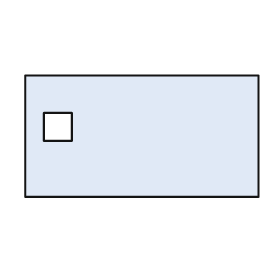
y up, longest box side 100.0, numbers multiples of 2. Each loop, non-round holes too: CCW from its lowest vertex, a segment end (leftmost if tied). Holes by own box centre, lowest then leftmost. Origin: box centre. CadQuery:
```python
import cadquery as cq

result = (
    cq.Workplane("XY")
    .moveTo(-50.0, -26.0)
    .lineTo(50.0, -26.0)
    .lineTo(50.0, 26.0)
    .lineTo(-50.0, 26.0)
    .close()
    .moveTo(-42.0, -2.0)
    .lineTo(-30.0, -2.0)
    .lineTo(-30.0, 10.0)
    .lineTo(-42.0, 10.0)
    .close()
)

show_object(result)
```